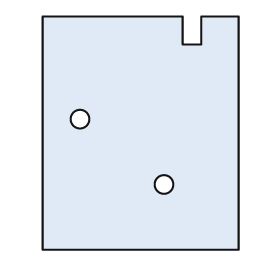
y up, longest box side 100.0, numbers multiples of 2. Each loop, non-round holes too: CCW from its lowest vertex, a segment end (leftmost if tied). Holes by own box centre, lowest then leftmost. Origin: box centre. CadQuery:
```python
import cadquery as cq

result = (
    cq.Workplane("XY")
    .moveTo(-42.0, -50.0)
    .lineTo(42.0, -50.0)
    .lineTo(42.0, 50.0)
    .lineTo(26.0, 50.0)
    .lineTo(26.0, 38.0)
    .lineTo(18.0, 38.0)
    .lineTo(18.0, 50.0)
    .lineTo(-42.0, 50.0)
    .close()
    .moveTo(10.0, -22.0)
    .circle(4.0)
    .moveTo(-26.0, 6.0)
    .circle(4.0)
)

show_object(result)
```